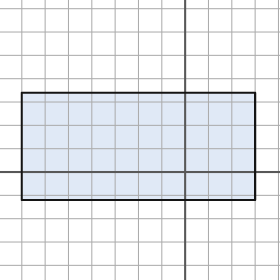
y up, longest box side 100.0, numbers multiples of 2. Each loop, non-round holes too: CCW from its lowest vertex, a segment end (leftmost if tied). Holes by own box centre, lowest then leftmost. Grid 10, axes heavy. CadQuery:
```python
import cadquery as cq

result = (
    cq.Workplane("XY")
    .moveTo(-70.0, -12.0)
    .lineTo(30.0, -12.0)
    .lineTo(30.0, 34.0)
    .lineTo(-70.0, 34.0)
    .close()
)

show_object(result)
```